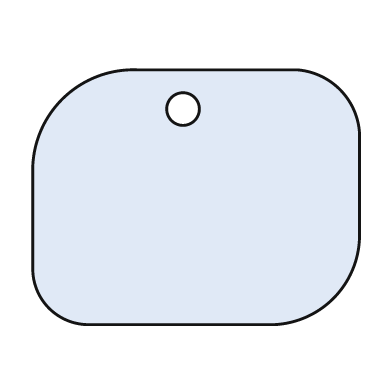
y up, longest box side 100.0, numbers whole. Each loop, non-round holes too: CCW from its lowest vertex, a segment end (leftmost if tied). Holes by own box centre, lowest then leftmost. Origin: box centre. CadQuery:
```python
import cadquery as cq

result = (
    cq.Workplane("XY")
    .moveTo(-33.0, -39.0)
    .lineTo(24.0, -39.0)
    .threePointArc((42.0, -31.0), (50.0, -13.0))
    .lineTo(50.0, 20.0)
    .threePointArc((44.0, 33.0), (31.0, 39.0))
    .lineTo(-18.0, 39.0)
    .threePointArc((-41.0, 30.0), (-50.0, 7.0))
    .lineTo(-50.0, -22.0)
    .threePointArc((-45.0, -34.0), (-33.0, -39.0))
    .close()
    .moveTo(-4.0, 27.0)
    .circle(5.0)
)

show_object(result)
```